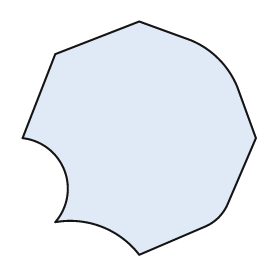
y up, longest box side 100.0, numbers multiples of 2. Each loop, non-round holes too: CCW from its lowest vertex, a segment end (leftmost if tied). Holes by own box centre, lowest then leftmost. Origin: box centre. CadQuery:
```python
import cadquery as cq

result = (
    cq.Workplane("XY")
    .moveTo(0.0, -50.0)
    .lineTo(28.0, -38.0)
    .threePointArc((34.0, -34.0), (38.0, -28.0))
    .lineTo(50.0, 0.0)
    .lineTo(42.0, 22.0)
    .threePointArc((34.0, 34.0), (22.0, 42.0))
    .lineTo(0.0, 50.0)
    .lineTo(-36.0, 36.0)
    .lineTo(-50.0, 0.0)
    .threePointArc((-32.0, -14.0), (-36.0, -36.0))
    .threePointArc((-16.0, -38.0), (0.0, -50.0))
    .close()
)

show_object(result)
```